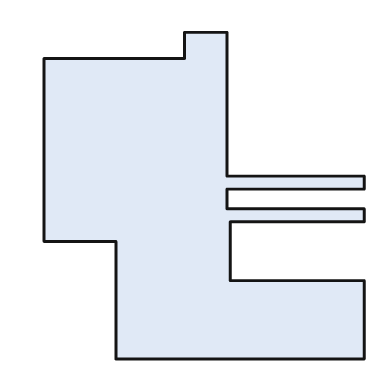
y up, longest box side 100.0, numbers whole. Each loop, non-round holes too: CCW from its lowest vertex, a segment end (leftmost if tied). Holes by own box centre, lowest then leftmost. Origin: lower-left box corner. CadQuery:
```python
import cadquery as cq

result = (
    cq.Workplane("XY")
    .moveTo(22.0, 0.0)
    .lineTo(98.0, 0.0)
    .lineTo(98.0, 24.0)
    .lineTo(57.0, 24.0)
    .lineTo(57.0, 42.0)
    .lineTo(98.0, 42.0)
    .lineTo(98.0, 46.0)
    .lineTo(56.0, 46.0)
    .lineTo(56.0, 52.0)
    .lineTo(98.0, 52.0)
    .lineTo(98.0, 56.0)
    .lineTo(56.0, 56.0)
    .lineTo(56.0, 100.0)
    .lineTo(43.0, 100.0)
    .lineTo(43.0, 92.0)
    .lineTo(0.0, 92.0)
    .lineTo(0.0, 36.0)
    .lineTo(22.0, 36.0)
    .close()
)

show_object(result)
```